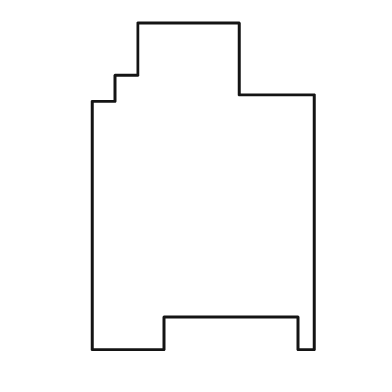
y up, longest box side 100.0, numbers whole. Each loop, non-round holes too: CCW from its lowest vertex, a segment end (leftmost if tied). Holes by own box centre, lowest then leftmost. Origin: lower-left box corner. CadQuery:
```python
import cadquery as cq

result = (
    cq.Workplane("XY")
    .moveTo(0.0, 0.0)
    .lineTo(22.0, 0.0)
    .lineTo(22.0, 10.0)
    .lineTo(63.0, 10.0)
    .lineTo(63.0, 0.0)
    .lineTo(68.0, 0.0)
    .lineTo(68.0, 78.0)
    .lineTo(45.0, 78.0)
    .lineTo(45.0, 100.0)
    .lineTo(14.0, 100.0)
    .lineTo(14.0, 84.0)
    .lineTo(7.0, 84.0)
    .lineTo(7.0, 76.0)
    .lineTo(0.0, 76.0)
    .close()
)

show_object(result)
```